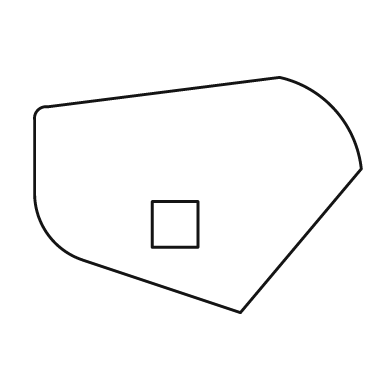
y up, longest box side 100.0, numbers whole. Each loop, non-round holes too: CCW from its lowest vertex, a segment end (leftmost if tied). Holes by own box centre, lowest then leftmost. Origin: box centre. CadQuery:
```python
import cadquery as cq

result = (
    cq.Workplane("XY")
    .moveTo(13.0, -36.0)
    .lineTo(50.0, 8.0)
    .threePointArc((42.0, 26.0), (25.0, 36.0))
    .lineTo(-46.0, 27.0)
    .threePointArc((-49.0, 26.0), (-50.0, 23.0))
    .lineTo(-50.0, 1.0)
    .threePointArc((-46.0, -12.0), (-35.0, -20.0))
    .close()
    .moveTo(-14.0, -16.0)
    .lineTo(0.0, -16.0)
    .lineTo(0.0, -2.0)
    .lineTo(-14.0, -2.0)
    .close()
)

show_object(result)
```